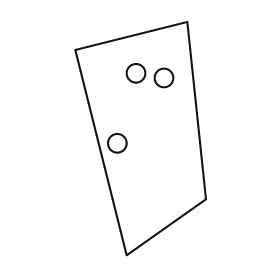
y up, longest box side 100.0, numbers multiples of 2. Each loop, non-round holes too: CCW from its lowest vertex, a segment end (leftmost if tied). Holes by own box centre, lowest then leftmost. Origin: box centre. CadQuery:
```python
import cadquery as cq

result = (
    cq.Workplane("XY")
    .moveTo(-6.0, -50.0)
    .lineTo(28.0, -26.0)
    .lineTo(20.0, 50.0)
    .lineTo(-28.0, 38.0)
    .close()
    .moveTo(-10.0, -2.0)
    .circle(4.0)
    .moveTo(10.0, 26.0)
    .circle(4.0)
    .moveTo(-2.0, 28.0)
    .circle(4.0)
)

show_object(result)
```